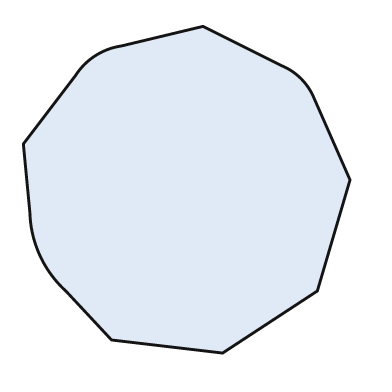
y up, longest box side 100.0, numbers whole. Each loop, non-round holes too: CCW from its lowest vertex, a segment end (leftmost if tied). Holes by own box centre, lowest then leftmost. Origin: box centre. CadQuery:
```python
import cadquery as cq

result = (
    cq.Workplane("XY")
    .moveTo(11.0, -50.0)
    .lineTo(40.0, -31.0)
    .lineTo(50.0, 3.0)
    .lineTo(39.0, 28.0)
    .threePointArc((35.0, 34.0), (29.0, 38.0))
    .lineTo(5.0, 50.0)
    .lineTo(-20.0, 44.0)
    .threePointArc((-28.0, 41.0), (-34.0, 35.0))
    .lineTo(-50.0, 14.0)
    .lineTo(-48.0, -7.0)
    .threePointArc((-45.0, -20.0), (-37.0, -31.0))
    .lineTo(-23.0, -46.0)
    .close()
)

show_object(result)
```